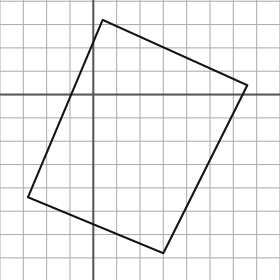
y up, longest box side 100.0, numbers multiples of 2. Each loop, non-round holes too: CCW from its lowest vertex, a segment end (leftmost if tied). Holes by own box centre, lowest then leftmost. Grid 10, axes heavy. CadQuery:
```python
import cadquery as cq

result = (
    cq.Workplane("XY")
    .moveTo(30.0, -68.0)
    .lineTo(66.0, 4.0)
    .lineTo(4.0, 32.0)
    .lineTo(-28.0, -44.0)
    .close()
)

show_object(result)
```